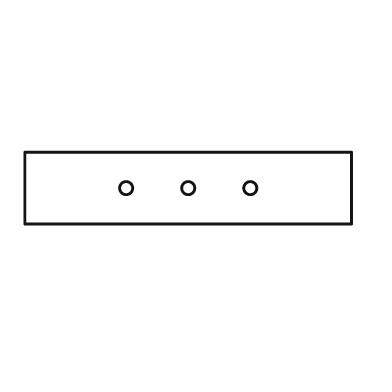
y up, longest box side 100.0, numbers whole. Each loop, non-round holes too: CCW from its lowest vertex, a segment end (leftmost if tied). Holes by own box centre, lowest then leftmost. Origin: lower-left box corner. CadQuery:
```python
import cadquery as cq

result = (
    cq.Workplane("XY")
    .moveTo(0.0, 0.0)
    .lineTo(100.0, 0.0)
    .lineTo(100.0, 22.0)
    .lineTo(0.0, 22.0)
    .close()
    .moveTo(31.0, 11.0)
    .circle(2.0)
    .moveTo(50.0, 11.0)
    .circle(2.0)
    .moveTo(69.0, 11.0)
    .circle(2.0)
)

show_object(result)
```